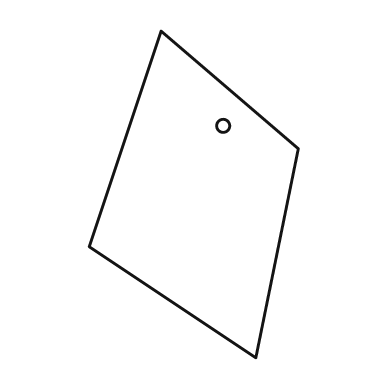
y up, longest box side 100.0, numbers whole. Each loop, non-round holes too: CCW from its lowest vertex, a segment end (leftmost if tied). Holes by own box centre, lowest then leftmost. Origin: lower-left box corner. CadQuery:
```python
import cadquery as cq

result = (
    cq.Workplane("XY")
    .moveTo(51.0, 0.0)
    .lineTo(64.0, 64.0)
    .lineTo(22.0, 100.0)
    .lineTo(0.0, 34.0)
    .close()
    .moveTo(41.0, 71.0)
    .circle(2.0)
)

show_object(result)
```